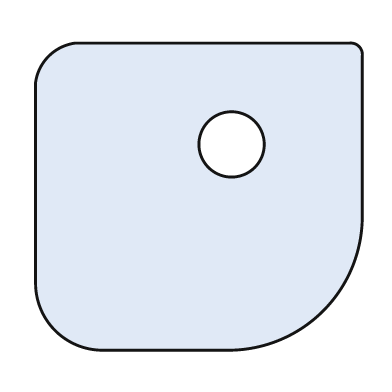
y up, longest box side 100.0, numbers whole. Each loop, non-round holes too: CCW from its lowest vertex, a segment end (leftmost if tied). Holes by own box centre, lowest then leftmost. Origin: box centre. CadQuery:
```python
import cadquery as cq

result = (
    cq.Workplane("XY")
    .moveTo(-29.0, -47.0)
    .lineTo(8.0, -47.0)
    .threePointArc((38.0, -35.0), (50.0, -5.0))
    .lineTo(50.0, 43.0)
    .threePointArc((49.0, 46.0), (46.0, 47.0))
    .lineTo(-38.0, 47.0)
    .threePointArc((-46.0, 43.0), (-50.0, 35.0))
    .lineTo(-50.0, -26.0)
    .threePointArc((-44.0, -41.0), (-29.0, -47.0))
    .close()
    .moveTo(10.0, 16.0)
    .circle(10.0)
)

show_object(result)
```